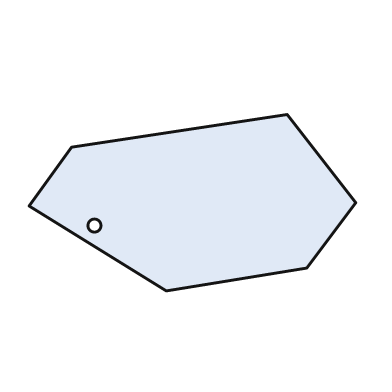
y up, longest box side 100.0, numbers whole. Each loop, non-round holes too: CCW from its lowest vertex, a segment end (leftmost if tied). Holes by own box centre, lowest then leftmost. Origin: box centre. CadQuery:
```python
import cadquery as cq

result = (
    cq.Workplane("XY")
    .moveTo(-8.0, -27.0)
    .lineTo(35.0, -20.0)
    .lineTo(50.0, 0.0)
    .lineTo(29.0, 27.0)
    .lineTo(-37.0, 17.0)
    .lineTo(-50.0, -1.0)
    .close()
    .moveTo(-30.0, -7.0)
    .circle(2.0)
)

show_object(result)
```